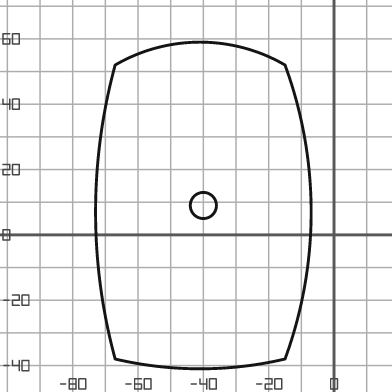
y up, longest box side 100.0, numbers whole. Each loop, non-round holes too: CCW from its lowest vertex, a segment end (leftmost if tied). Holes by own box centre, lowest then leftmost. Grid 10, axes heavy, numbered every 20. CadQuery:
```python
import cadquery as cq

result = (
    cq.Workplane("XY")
    .moveTo(-67.0, -38.0)
    .threePointArc((-41.0, -41.0), (-15.0, -38.0))
    .threePointArc((-7.0, 7.0), (-15.0, 52.0))
    .threePointArc((-41.0, 59.0), (-67.0, 52.0))
    .threePointArc((-73.0, 7.0), (-67.0, -38.0))
    .close()
    .moveTo(-40.0, 9.0)
    .circle(4.0)
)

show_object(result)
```